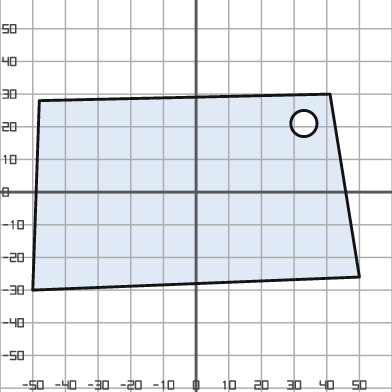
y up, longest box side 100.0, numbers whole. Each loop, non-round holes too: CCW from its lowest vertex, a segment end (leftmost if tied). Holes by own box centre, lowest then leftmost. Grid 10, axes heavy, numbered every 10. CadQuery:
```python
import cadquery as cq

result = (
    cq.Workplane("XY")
    .moveTo(-50.0, -30.0)
    .lineTo(50.0, -26.0)
    .lineTo(41.0, 30.0)
    .lineTo(-48.0, 28.0)
    .close()
    .moveTo(33.0, 21.0)
    .circle(4.0)
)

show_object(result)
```